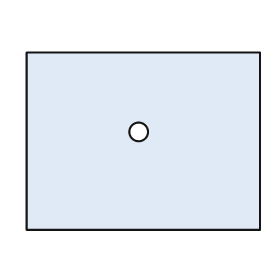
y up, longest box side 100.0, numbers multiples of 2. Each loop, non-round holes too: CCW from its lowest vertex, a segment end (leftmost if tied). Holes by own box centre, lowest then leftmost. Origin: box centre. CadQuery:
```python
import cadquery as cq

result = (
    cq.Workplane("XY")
    .moveTo(-50.0, -38.0)
    .lineTo(50.0, -38.0)
    .lineTo(50.0, 38.0)
    .lineTo(-50.0, 38.0)
    .close()
    .moveTo(-2.0, 4.0)
    .circle(4.0)
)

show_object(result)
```